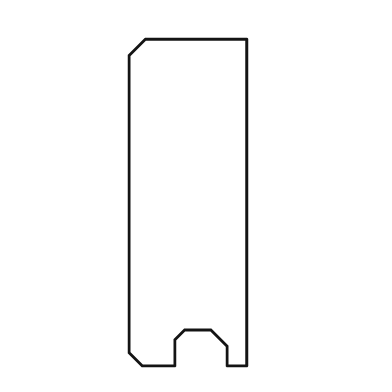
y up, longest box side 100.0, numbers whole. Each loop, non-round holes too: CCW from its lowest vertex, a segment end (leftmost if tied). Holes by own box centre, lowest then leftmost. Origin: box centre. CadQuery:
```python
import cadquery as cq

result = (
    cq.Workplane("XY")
    .moveTo(-14.0, -50.0)
    .lineTo(-4.0, -50.0)
    .lineTo(-4.0, -42.0)
    .lineTo(-1.0, -39.0)
    .lineTo(7.0, -39.0)
    .lineTo(12.0, -44.0)
    .lineTo(12.0, -50.0)
    .lineTo(18.0, -50.0)
    .lineTo(18.0, 50.0)
    .lineTo(-13.0, 50.0)
    .lineTo(-18.0, 45.0)
    .lineTo(-18.0, -46.0)
    .close()
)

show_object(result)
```